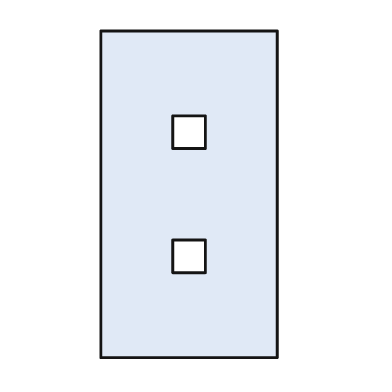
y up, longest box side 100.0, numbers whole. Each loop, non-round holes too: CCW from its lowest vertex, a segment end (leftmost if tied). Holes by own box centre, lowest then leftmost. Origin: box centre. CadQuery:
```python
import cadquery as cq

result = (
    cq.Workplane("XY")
    .moveTo(-27.0, -50.0)
    .lineTo(27.0, -50.0)
    .lineTo(27.0, 50.0)
    .lineTo(-27.0, 50.0)
    .close()
    .moveTo(-5.0, -24.0)
    .lineTo(5.0, -24.0)
    .lineTo(5.0, -14.0)
    .lineTo(-5.0, -14.0)
    .close()
    .moveTo(-5.0, 14.0)
    .lineTo(5.0, 14.0)
    .lineTo(5.0, 24.0)
    .lineTo(-5.0, 24.0)
    .close()
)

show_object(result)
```